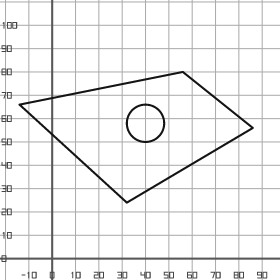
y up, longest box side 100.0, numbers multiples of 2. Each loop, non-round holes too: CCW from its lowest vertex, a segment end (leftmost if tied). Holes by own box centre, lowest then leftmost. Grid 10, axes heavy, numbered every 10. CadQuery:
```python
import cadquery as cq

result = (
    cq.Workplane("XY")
    .moveTo(32.0, 24.0)
    .lineTo(86.0, 56.0)
    .lineTo(56.0, 80.0)
    .lineTo(-14.0, 66.0)
    .close()
    .moveTo(40.0, 58.0)
    .circle(8.0)
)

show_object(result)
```